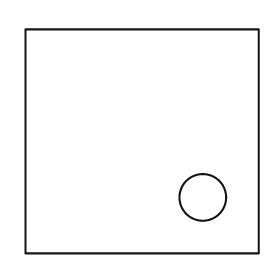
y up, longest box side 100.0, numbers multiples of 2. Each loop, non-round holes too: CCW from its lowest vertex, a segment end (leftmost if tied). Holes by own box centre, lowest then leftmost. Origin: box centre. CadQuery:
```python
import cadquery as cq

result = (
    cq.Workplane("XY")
    .moveTo(-50.0, -48.0)
    .lineTo(50.0, -48.0)
    .lineTo(50.0, 48.0)
    .lineTo(-50.0, 48.0)
    .close()
    .moveTo(26.0, -24.0)
    .circle(10.0)
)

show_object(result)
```